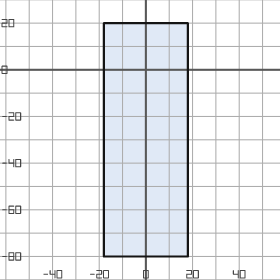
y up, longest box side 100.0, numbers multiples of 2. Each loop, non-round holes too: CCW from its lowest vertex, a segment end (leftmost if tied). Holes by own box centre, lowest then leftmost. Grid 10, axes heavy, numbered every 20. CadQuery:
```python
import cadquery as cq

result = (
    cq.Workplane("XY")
    .moveTo(-18.0, -80.0)
    .lineTo(18.0, -80.0)
    .lineTo(18.0, 20.0)
    .lineTo(-18.0, 20.0)
    .close()
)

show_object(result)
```